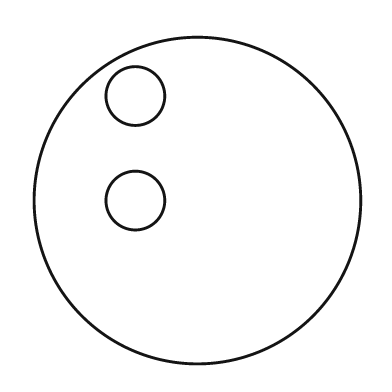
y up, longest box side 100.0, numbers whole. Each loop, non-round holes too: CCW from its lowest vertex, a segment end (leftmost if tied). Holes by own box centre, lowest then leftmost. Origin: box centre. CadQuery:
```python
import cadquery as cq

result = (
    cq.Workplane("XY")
    .moveTo(0.0, 0.0)
    .circle(50.0)
    .moveTo(-19.0, 0.0)
    .circle(9.0)
    .moveTo(-19.0, 32.0)
    .circle(9.0)
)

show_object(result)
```